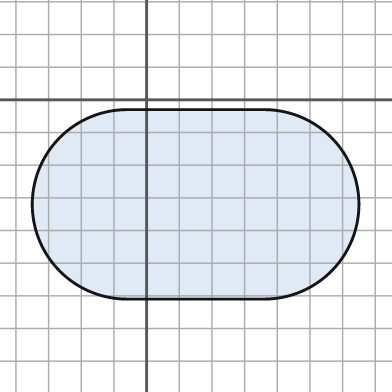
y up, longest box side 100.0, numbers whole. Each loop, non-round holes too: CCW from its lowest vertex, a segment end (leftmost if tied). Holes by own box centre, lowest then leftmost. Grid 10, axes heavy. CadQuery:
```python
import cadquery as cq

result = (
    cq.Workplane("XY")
    .moveTo(-6.0, -61.0)
    .lineTo(36.0, -61.0)
    .threePointArc((65.0, -32.0), (36.0, -3.0))
    .lineTo(-6.0, -3.0)
    .threePointArc((-35.0, -32.0), (-6.0, -61.0))
    .close()
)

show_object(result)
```